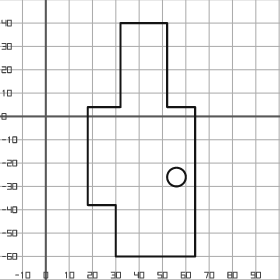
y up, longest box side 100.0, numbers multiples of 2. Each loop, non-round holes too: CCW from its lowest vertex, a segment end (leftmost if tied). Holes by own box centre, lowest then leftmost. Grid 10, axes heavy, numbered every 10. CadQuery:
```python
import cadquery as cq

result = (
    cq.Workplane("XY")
    .moveTo(30.0, -60.0)
    .lineTo(64.0, -60.0)
    .lineTo(64.0, 4.0)
    .lineTo(52.0, 4.0)
    .lineTo(52.0, 40.0)
    .lineTo(32.0, 40.0)
    .lineTo(32.0, 4.0)
    .lineTo(18.0, 4.0)
    .lineTo(18.0, -38.0)
    .lineTo(30.0, -38.0)
    .close()
    .moveTo(56.0, -26.0)
    .circle(4.0)
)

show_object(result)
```